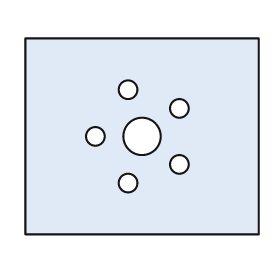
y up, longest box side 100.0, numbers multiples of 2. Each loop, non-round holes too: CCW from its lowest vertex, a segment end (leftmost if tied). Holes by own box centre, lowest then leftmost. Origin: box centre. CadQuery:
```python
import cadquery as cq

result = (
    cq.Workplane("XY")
    .moveTo(-50.0, -42.0)
    .lineTo(50.0, -42.0)
    .lineTo(50.0, 42.0)
    .lineTo(-50.0, 42.0)
    .close()
    .moveTo(-6.0, -20.0)
    .circle(4.0)
    .moveTo(16.0, -12.0)
    .circle(4.0)
    .moveTo(-20.0, 0.0)
    .circle(4.0)
    .moveTo(0.0, 0.0)
    .circle(8.0)
    .moveTo(16.0, 12.0)
    .circle(4.0)
    .moveTo(-6.0, 20.0)
    .circle(4.0)
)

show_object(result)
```